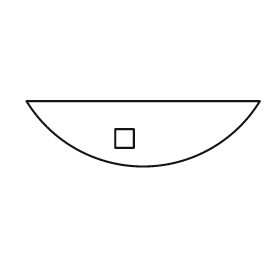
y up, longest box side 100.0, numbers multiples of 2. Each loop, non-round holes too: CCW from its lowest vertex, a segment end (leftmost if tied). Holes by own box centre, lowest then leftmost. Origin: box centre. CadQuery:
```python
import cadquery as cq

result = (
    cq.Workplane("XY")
    .moveTo(-50.0, 14.0)
    .threePointArc((0.0, -14.0), (50.0, 14.0))
    .close()
    .moveTo(-12.0, -6.0)
    .lineTo(-4.0, -6.0)
    .lineTo(-4.0, 2.0)
    .lineTo(-12.0, 2.0)
    .close()
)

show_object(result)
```